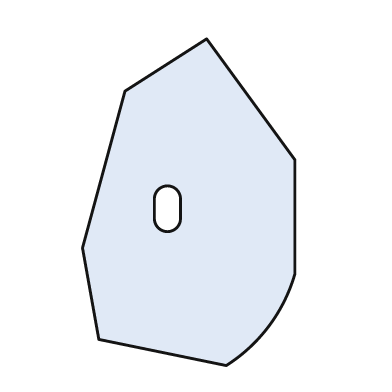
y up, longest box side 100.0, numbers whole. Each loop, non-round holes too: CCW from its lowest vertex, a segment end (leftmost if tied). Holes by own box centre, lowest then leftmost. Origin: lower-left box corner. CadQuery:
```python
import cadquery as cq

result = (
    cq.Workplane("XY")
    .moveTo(44.0, 0.0)
    .threePointArc((57.0, 12.0), (65.0, 28.0))
    .lineTo(65.0, 63.0)
    .lineTo(38.0, 100.0)
    .lineTo(13.0, 84.0)
    .lineTo(0.0, 36.0)
    .lineTo(5.0, 8.0)
    .close()
    .moveTo(22.0, 45.0)
    .threePointArc((26.0, 41.0), (30.0, 45.0))
    .lineTo(30.0, 51.0)
    .threePointArc((26.0, 55.0), (22.0, 51.0))
    .close()
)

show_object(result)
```